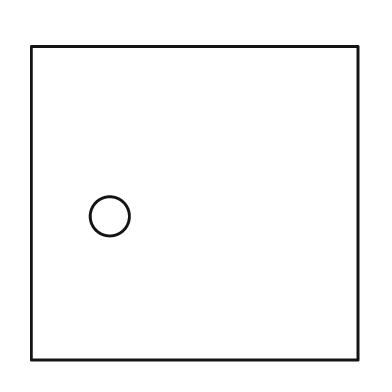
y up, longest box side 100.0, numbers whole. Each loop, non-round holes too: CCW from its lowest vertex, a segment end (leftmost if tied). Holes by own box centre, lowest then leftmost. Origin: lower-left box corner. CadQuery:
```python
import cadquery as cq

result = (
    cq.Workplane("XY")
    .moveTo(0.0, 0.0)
    .lineTo(100.0, 0.0)
    .lineTo(100.0, 96.0)
    .lineTo(0.0, 96.0)
    .close()
    .moveTo(24.0, 44.0)
    .circle(6.0)
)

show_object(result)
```